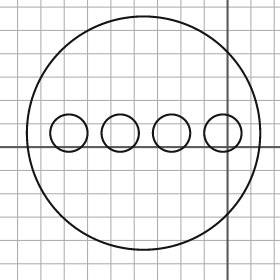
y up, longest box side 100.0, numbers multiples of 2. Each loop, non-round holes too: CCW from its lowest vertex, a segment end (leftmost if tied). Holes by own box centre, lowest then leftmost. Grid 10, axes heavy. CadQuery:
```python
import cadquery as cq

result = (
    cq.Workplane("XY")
    .moveTo(-36.0, 6.0)
    .circle(50.0)
    .moveTo(-68.0, 6.0)
    .circle(8.0)
    .moveTo(-46.0, 6.0)
    .circle(8.0)
    .moveTo(-24.0, 6.0)
    .circle(8.0)
    .moveTo(-2.0, 6.0)
    .circle(8.0)
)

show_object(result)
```